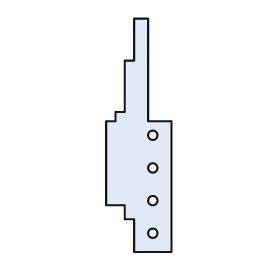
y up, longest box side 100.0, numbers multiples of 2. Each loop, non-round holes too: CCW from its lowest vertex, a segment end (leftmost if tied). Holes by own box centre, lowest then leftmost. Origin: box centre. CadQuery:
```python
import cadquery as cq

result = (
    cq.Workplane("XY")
    .moveTo(-2.0, -50.0)
    .lineTo(14.0, -50.0)
    .lineTo(14.0, 6.0)
    .lineTo(4.0, 6.0)
    .lineTo(4.0, 50.0)
    .lineTo(-2.0, 50.0)
    .lineTo(-2.0, 32.0)
    .lineTo(-6.0, 32.0)
    .lineTo(-6.0, 10.0)
    .lineTo(-10.0, 10.0)
    .lineTo(-10.0, 6.0)
    .lineTo(-14.0, 6.0)
    .lineTo(-14.0, -30.0)
    .lineTo(-6.0, -30.0)
    .lineTo(-6.0, -36.0)
    .lineTo(-2.0, -36.0)
    .close()
    .moveTo(6.0, -42.0)
    .circle(2.0)
    .moveTo(6.0, -28.0)
    .circle(2.0)
    .moveTo(6.0, -14.0)
    .circle(2.0)
    .moveTo(6.0, 0.0)
    .circle(2.0)
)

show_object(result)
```